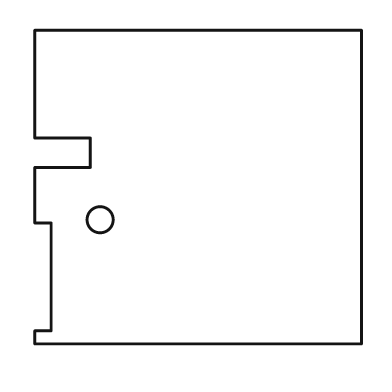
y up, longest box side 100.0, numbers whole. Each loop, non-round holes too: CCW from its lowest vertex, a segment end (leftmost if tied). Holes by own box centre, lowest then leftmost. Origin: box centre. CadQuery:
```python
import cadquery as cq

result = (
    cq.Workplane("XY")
    .moveTo(-50.0, -48.0)
    .lineTo(50.0, -48.0)
    .lineTo(50.0, 48.0)
    .lineTo(-50.0, 48.0)
    .lineTo(-50.0, 15.0)
    .lineTo(-33.0, 15.0)
    .lineTo(-33.0, 6.0)
    .lineTo(-50.0, 6.0)
    .lineTo(-50.0, -11.0)
    .lineTo(-45.0, -11.0)
    .lineTo(-45.0, -44.0)
    .lineTo(-50.0, -44.0)
    .close()
    .moveTo(-30.0, -10.0)
    .circle(4.0)
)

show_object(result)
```